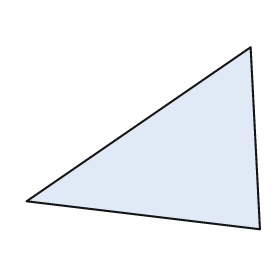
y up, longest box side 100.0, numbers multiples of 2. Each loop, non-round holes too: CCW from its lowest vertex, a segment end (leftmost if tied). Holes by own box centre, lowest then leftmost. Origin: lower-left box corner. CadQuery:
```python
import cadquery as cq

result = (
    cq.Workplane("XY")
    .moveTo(100.0, 0.0)
    .lineTo(96.0, 78.0)
    .lineTo(0.0, 12.0)
    .close()
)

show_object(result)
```